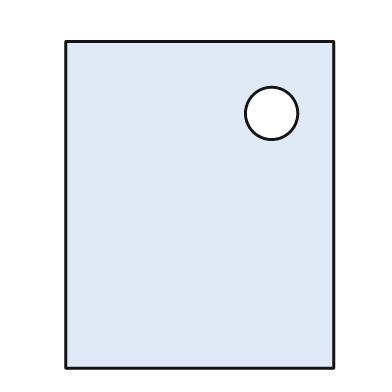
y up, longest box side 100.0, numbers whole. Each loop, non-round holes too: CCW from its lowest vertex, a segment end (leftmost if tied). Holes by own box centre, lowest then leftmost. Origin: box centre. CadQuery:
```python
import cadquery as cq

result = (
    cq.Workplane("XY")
    .moveTo(-41.0, -50.0)
    .lineTo(41.0, -50.0)
    .lineTo(41.0, 50.0)
    .lineTo(-41.0, 50.0)
    .close()
    .moveTo(22.0, 28.0)
    .circle(8.0)
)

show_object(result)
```